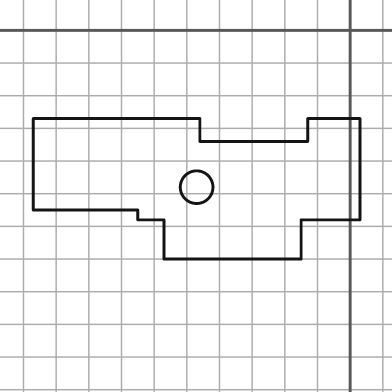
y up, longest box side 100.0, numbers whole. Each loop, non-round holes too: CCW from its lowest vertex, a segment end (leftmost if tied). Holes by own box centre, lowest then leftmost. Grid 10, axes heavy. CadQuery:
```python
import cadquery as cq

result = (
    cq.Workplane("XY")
    .moveTo(-57.0, -70.0)
    .lineTo(-15.0, -70.0)
    .lineTo(-15.0, -58.0)
    .lineTo(3.0, -58.0)
    .lineTo(3.0, -27.0)
    .lineTo(-13.0, -27.0)
    .lineTo(-13.0, -34.0)
    .lineTo(-46.0, -34.0)
    .lineTo(-46.0, -27.0)
    .lineTo(-97.0, -27.0)
    .lineTo(-97.0, -55.0)
    .lineTo(-65.0, -55.0)
    .lineTo(-65.0, -58.0)
    .lineTo(-57.0, -58.0)
    .close()
    .moveTo(-47.0, -48.0)
    .circle(5.0)
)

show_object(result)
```